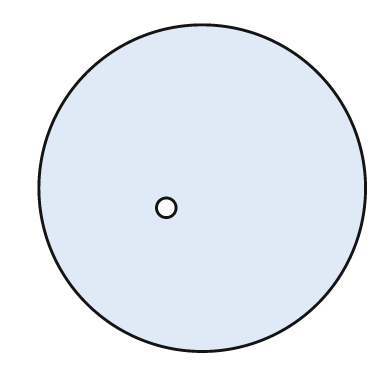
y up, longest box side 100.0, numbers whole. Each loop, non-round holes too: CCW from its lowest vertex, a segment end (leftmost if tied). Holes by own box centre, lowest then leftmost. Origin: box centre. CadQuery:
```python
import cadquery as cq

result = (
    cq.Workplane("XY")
    .moveTo(0.0, 0.0)
    .circle(50.0)
    .moveTo(-11.0, -6.0)
    .circle(3.0)
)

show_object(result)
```